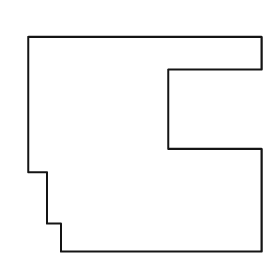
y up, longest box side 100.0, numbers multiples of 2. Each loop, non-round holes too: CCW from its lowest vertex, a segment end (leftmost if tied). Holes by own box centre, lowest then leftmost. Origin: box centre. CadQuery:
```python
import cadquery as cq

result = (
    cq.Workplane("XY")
    .moveTo(-36.0, -46.0)
    .lineTo(50.0, -46.0)
    .lineTo(50.0, -2.0)
    .lineTo(10.0, -2.0)
    .lineTo(10.0, 32.0)
    .lineTo(50.0, 32.0)
    .lineTo(50.0, 46.0)
    .lineTo(-50.0, 46.0)
    .lineTo(-50.0, -12.0)
    .lineTo(-42.0, -12.0)
    .lineTo(-42.0, -34.0)
    .lineTo(-36.0, -34.0)
    .close()
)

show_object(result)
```